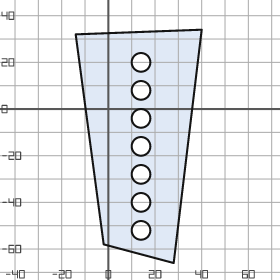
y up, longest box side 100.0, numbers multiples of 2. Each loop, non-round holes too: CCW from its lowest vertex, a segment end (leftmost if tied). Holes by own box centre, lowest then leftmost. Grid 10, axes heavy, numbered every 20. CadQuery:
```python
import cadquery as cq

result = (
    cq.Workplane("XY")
    .moveTo(28.0, -66.0)
    .lineTo(40.0, 34.0)
    .lineTo(-14.0, 32.0)
    .lineTo(-2.0, -58.0)
    .close()
    .moveTo(14.0, -52.0)
    .circle(4.0)
    .moveTo(14.0, -40.0)
    .circle(4.0)
    .moveTo(14.0, -28.0)
    .circle(4.0)
    .moveTo(14.0, -16.0)
    .circle(4.0)
    .moveTo(14.0, -4.0)
    .circle(4.0)
    .moveTo(14.0, 8.0)
    .circle(4.0)
    .moveTo(14.0, 20.0)
    .circle(4.0)
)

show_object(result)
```